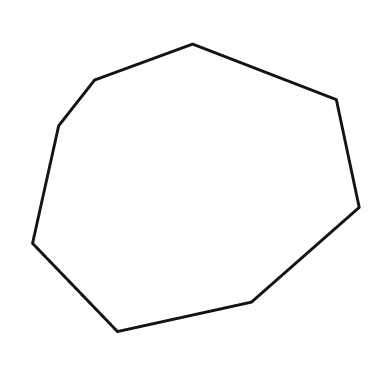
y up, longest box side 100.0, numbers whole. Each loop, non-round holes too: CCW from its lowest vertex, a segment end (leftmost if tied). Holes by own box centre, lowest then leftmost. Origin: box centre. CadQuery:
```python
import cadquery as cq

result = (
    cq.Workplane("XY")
    .moveTo(-24.0, -44.0)
    .lineTo(17.0, -35.0)
    .lineTo(50.0, -6.0)
    .lineTo(43.0, 27.0)
    .lineTo(-1.0, 44.0)
    .lineTo(-31.0, 33.0)
    .lineTo(-42.0, 19.0)
    .lineTo(-50.0, -17.0)
    .close()
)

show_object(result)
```